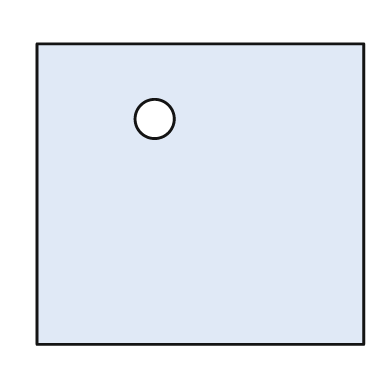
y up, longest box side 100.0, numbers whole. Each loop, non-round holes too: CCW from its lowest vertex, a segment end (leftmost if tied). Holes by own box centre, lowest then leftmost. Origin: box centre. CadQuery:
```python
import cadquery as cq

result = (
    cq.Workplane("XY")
    .moveTo(-50.0, -46.0)
    .lineTo(50.0, -46.0)
    .lineTo(50.0, 46.0)
    .lineTo(-50.0, 46.0)
    .close()
    .moveTo(-14.0, 23.0)
    .circle(6.0)
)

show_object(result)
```